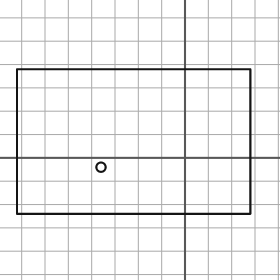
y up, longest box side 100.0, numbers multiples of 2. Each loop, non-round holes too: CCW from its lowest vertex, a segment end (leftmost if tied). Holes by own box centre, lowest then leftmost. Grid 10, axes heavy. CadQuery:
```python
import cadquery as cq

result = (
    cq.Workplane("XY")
    .moveTo(-72.0, -24.0)
    .lineTo(28.0, -24.0)
    .lineTo(28.0, 38.0)
    .lineTo(-72.0, 38.0)
    .close()
    .moveTo(-36.0, -4.0)
    .circle(2.0)
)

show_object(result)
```